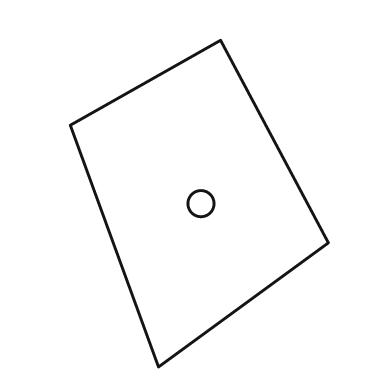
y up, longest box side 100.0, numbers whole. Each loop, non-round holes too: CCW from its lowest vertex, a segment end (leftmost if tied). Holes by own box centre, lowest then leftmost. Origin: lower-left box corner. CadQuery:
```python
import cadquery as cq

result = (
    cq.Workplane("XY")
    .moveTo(27.0, 0.0)
    .lineTo(79.0, 38.0)
    .lineTo(46.0, 100.0)
    .lineTo(0.0, 74.0)
    .close()
    .moveTo(40.0, 50.0)
    .circle(4.0)
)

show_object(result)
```